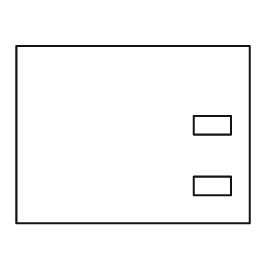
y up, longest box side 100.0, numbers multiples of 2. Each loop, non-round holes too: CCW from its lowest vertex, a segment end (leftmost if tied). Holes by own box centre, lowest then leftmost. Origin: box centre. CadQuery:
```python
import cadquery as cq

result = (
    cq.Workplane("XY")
    .moveTo(-50.0, -38.0)
    .lineTo(50.0, -38.0)
    .lineTo(50.0, 38.0)
    .lineTo(-50.0, 38.0)
    .close()
    .moveTo(26.0, -26.0)
    .lineTo(42.0, -26.0)
    .lineTo(42.0, -18.0)
    .lineTo(26.0, -18.0)
    .close()
    .moveTo(26.0, 0.0)
    .lineTo(42.0, 0.0)
    .lineTo(42.0, 8.0)
    .lineTo(26.0, 8.0)
    .close()
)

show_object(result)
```